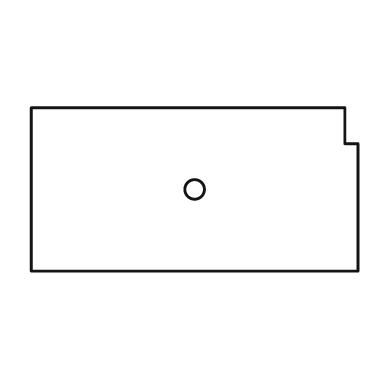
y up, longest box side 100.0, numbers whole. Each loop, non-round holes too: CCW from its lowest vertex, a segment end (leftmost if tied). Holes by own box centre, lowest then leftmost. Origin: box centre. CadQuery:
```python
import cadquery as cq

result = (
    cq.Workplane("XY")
    .moveTo(-50.0, -25.0)
    .lineTo(50.0, -25.0)
    .lineTo(50.0, 14.0)
    .lineTo(46.0, 14.0)
    .lineTo(46.0, 25.0)
    .lineTo(-50.0, 25.0)
    .close()
    .moveTo(0.0, 0.0)
    .circle(3.0)
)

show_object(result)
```